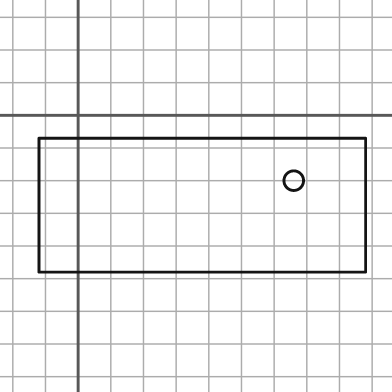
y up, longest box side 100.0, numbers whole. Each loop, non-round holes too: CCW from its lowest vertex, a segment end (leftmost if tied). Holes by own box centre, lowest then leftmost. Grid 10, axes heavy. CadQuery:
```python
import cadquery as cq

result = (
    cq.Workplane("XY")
    .moveTo(-12.0, -48.0)
    .lineTo(88.0, -48.0)
    .lineTo(88.0, -7.0)
    .lineTo(-12.0, -7.0)
    .close()
    .moveTo(66.0, -20.0)
    .circle(3.0)
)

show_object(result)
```